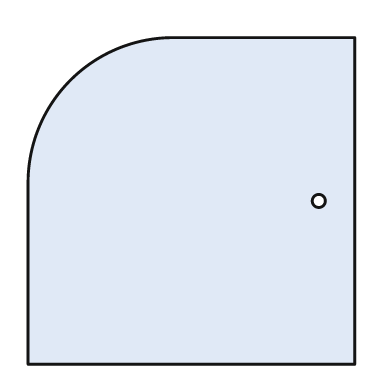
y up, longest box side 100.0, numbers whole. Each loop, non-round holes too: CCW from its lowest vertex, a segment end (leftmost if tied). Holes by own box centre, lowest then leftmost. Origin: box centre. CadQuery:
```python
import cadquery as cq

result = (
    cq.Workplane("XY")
    .moveTo(-50.0, -50.0)
    .lineTo(50.0, -50.0)
    .lineTo(50.0, 50.0)
    .lineTo(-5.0, 50.0)
    .threePointArc((-37.0, 37.0), (-50.0, 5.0))
    .close()
    .moveTo(39.0, 0.0)
    .circle(2.0)
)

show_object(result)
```